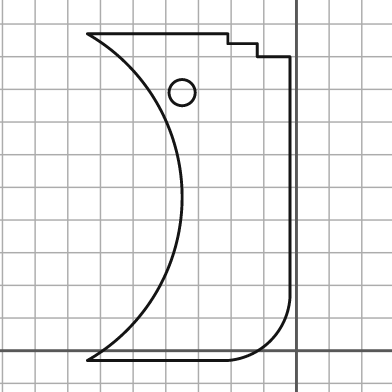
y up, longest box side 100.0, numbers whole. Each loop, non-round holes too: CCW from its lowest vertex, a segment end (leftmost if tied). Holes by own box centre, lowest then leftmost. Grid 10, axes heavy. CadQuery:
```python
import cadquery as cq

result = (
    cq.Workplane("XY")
    .moveTo(-64.0, -3.0)
    .lineTo(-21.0, -3.0)
    .threePointArc((-8.0, 3.0), (-2.0, 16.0))
    .lineTo(-2.0, 90.0)
    .lineTo(-12.0, 90.0)
    .lineTo(-12.0, 94.0)
    .lineTo(-21.0, 94.0)
    .lineTo(-21.0, 97.0)
    .lineTo(-64.0, 97.0)
    .threePointArc((-35.0, 47.0), (-64.0, -3.0))
    .close()
    .moveTo(-35.0, 79.0)
    .circle(4.0)
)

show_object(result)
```